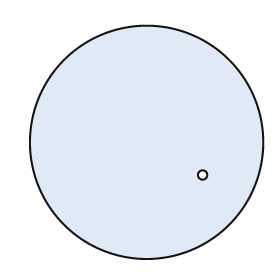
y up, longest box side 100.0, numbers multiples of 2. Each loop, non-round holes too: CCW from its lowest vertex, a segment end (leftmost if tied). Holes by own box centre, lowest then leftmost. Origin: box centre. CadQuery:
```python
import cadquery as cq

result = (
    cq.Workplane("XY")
    .moveTo(0.0, 0.0)
    .circle(50.0)
    .moveTo(24.0, -14.0)
    .circle(2.0)
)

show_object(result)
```